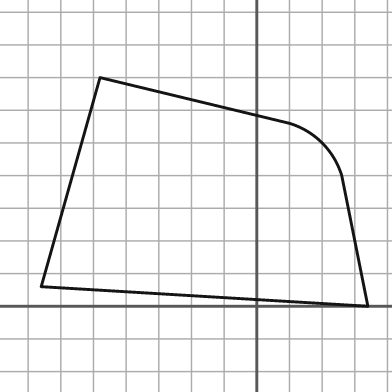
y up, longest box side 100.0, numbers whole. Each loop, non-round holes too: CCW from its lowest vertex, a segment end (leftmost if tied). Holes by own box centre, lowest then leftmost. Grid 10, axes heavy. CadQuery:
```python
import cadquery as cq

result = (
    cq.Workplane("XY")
    .moveTo(34.0, 0.0)
    .lineTo(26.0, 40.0)
    .threePointArc((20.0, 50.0), (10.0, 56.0))
    .lineTo(-48.0, 70.0)
    .lineTo(-66.0, 6.0)
    .close()
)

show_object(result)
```